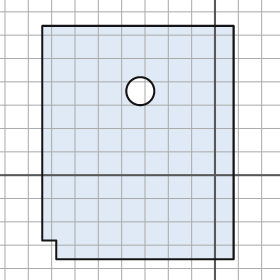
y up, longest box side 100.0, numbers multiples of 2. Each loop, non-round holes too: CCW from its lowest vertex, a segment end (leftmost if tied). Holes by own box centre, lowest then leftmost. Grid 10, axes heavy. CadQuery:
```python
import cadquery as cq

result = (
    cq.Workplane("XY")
    .moveTo(-68.0, -36.0)
    .lineTo(8.0, -36.0)
    .lineTo(8.0, 64.0)
    .lineTo(-74.0, 64.0)
    .lineTo(-74.0, -28.0)
    .lineTo(-68.0, -28.0)
    .close()
    .moveTo(-32.0, 36.0)
    .circle(6.0)
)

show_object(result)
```